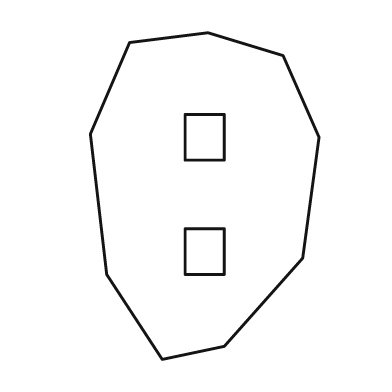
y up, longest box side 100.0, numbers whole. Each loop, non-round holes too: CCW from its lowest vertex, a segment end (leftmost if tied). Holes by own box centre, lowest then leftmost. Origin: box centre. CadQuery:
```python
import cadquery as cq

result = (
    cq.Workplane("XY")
    .moveTo(-13.0, -50.0)
    .lineTo(6.0, -46.0)
    .lineTo(30.0, -19.0)
    .lineTo(35.0, 18.0)
    .lineTo(24.0, 43.0)
    .lineTo(1.0, 50.0)
    .lineTo(-23.0, 47.0)
    .lineTo(-35.0, 19.0)
    .lineTo(-30.0, -24.0)
    .close()
    .moveTo(-6.0, -24.0)
    .lineTo(6.0, -24.0)
    .lineTo(6.0, -10.0)
    .lineTo(-6.0, -10.0)
    .close()
    .moveTo(-6.0, 11.0)
    .lineTo(6.0, 11.0)
    .lineTo(6.0, 25.0)
    .lineTo(-6.0, 25.0)
    .close()
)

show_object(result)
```